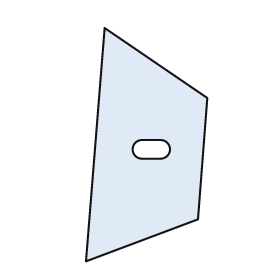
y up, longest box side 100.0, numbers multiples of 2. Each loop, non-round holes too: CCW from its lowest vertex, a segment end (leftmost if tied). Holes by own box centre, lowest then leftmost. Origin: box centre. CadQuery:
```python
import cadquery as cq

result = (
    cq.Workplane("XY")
    .moveTo(-26.0, -50.0)
    .lineTo(22.0, -32.0)
    .lineTo(26.0, 20.0)
    .lineTo(-18.0, 50.0)
    .close()
    .moveTo(-2.0, -6.0)
    .lineTo(6.0, -6.0)
    .threePointArc((10.0, -2.0), (6.0, 2.0))
    .lineTo(-2.0, 2.0)
    .threePointArc((-6.0, -2.0), (-2.0, -6.0))
    .close()
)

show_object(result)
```